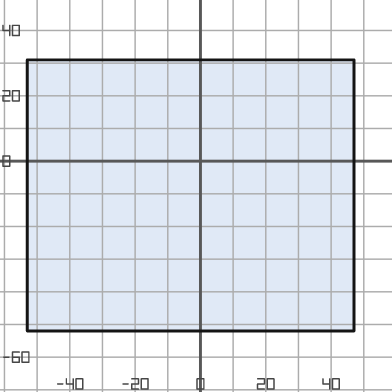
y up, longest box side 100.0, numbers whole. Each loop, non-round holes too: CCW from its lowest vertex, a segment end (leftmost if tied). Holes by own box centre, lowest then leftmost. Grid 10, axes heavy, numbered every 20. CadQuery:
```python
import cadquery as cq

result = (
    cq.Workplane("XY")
    .moveTo(-53.0, -52.0)
    .lineTo(47.0, -52.0)
    .lineTo(47.0, 31.0)
    .lineTo(-53.0, 31.0)
    .close()
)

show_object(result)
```